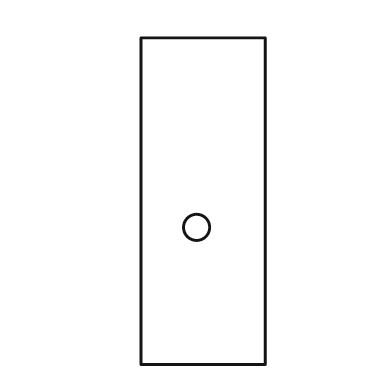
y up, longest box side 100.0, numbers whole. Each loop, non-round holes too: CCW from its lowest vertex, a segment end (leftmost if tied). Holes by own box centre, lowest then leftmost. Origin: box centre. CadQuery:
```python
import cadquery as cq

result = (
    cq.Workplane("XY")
    .moveTo(-19.0, -50.0)
    .lineTo(19.0, -50.0)
    .lineTo(19.0, 50.0)
    .lineTo(-19.0, 50.0)
    .close()
    .moveTo(-2.0, -8.0)
    .circle(4.0)
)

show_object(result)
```